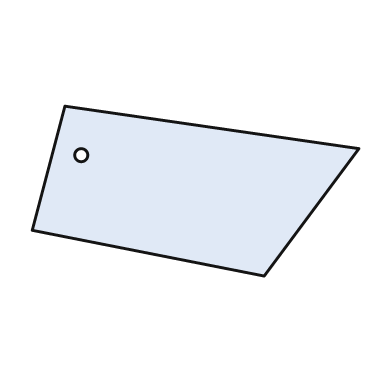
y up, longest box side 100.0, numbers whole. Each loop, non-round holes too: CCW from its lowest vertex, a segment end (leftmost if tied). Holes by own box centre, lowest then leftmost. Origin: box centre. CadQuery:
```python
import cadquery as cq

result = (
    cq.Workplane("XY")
    .moveTo(21.0, -26.0)
    .lineTo(50.0, 13.0)
    .lineTo(-40.0, 26.0)
    .lineTo(-50.0, -12.0)
    .close()
    .moveTo(-35.0, 11.0)
    .circle(2.0)
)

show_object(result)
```